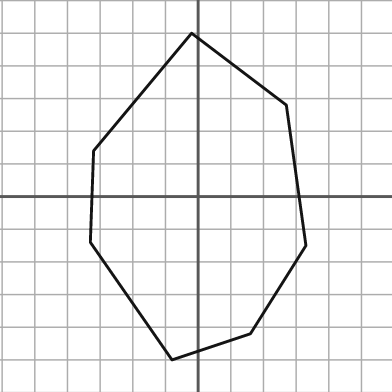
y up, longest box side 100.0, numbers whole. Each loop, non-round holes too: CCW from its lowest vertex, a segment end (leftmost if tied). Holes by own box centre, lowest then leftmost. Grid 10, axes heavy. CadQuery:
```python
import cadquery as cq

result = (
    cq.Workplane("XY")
    .moveTo(-8.0, -50.0)
    .lineTo(16.0, -42.0)
    .lineTo(33.0, -15.0)
    .lineTo(27.0, 28.0)
    .lineTo(-2.0, 50.0)
    .lineTo(-32.0, 14.0)
    .lineTo(-33.0, -14.0)
    .close()
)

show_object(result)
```